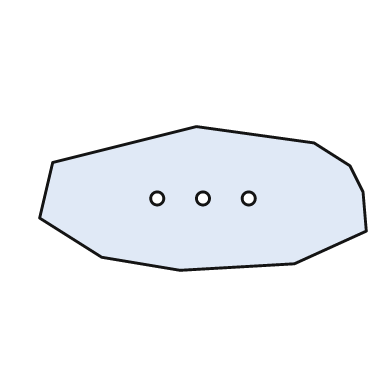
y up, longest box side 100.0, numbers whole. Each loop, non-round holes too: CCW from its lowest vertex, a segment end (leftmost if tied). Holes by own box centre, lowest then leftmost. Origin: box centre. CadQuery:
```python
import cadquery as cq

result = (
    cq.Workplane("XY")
    .moveTo(-7.0, -22.0)
    .lineTo(28.0, -20.0)
    .lineTo(50.0, -10.0)
    .lineTo(49.0, 2.0)
    .lineTo(45.0, 10.0)
    .lineTo(34.0, 17.0)
    .lineTo(-2.0, 22.0)
    .lineTo(-46.0, 11.0)
    .lineTo(-50.0, -6.0)
    .lineTo(-31.0, -18.0)
    .close()
    .moveTo(-14.0, 0.0)
    .circle(2.0)
    .moveTo(0.0, 0.0)
    .circle(2.0)
    .moveTo(14.0, 0.0)
    .circle(2.0)
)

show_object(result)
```